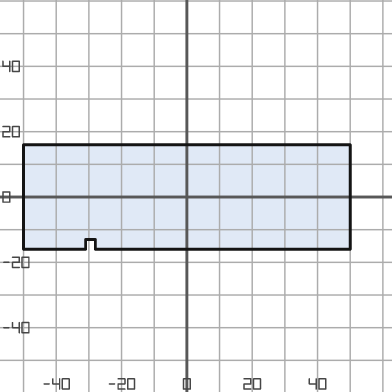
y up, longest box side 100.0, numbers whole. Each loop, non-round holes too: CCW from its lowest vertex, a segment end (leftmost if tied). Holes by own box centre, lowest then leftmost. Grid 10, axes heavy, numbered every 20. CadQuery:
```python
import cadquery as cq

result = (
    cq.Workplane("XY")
    .moveTo(-50.0, -16.0)
    .lineTo(-31.0, -16.0)
    .lineTo(-31.0, -13.0)
    .lineTo(-28.0, -13.0)
    .lineTo(-28.0, -16.0)
    .lineTo(50.0, -16.0)
    .lineTo(50.0, 16.0)
    .lineTo(-50.0, 16.0)
    .close()
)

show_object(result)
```